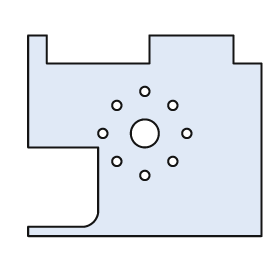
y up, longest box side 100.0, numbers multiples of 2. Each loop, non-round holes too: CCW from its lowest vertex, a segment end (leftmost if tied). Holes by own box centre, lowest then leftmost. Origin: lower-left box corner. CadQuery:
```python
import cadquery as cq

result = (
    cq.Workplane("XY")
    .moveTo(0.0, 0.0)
    .lineTo(100.0, 0.0)
    .lineTo(100.0, 74.0)
    .lineTo(88.0, 74.0)
    .lineTo(88.0, 86.0)
    .lineTo(52.0, 86.0)
    .lineTo(52.0, 74.0)
    .lineTo(8.0, 74.0)
    .lineTo(8.0, 86.0)
    .lineTo(0.0, 86.0)
    .lineTo(0.0, 38.0)
    .lineTo(30.0, 38.0)
    .lineTo(30.0, 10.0)
    .threePointArc((28.0, 6.0), (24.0, 4.0))
    .lineTo(0.0, 4.0)
    .close()
    .moveTo(50.0, 26.0)
    .circle(2.0)
    .moveTo(38.0, 32.0)
    .circle(2.0)
    .moveTo(62.0, 32.0)
    .circle(2.0)
    .moveTo(32.0, 44.0)
    .circle(2.0)
    .moveTo(50.0, 44.0)
    .circle(6.0)
    .moveTo(68.0, 44.0)
    .circle(2.0)
    .moveTo(38.0, 56.0)
    .circle(2.0)
    .moveTo(62.0, 56.0)
    .circle(2.0)
    .moveTo(50.0, 62.0)
    .circle(2.0)
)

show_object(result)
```